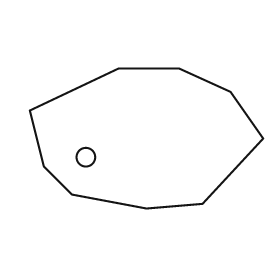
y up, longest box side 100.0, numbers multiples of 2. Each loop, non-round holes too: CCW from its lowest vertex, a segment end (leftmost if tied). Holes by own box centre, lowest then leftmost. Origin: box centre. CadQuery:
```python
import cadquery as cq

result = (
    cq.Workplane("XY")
    .moveTo(0.0, -30.0)
    .lineTo(24.0, -28.0)
    .lineTo(50.0, 0.0)
    .lineTo(36.0, 20.0)
    .lineTo(14.0, 30.0)
    .lineTo(-12.0, 30.0)
    .lineTo(-50.0, 12.0)
    .lineTo(-44.0, -12.0)
    .lineTo(-32.0, -24.0)
    .close()
    .moveTo(-26.0, -8.0)
    .circle(4.0)
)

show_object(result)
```